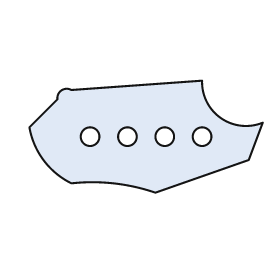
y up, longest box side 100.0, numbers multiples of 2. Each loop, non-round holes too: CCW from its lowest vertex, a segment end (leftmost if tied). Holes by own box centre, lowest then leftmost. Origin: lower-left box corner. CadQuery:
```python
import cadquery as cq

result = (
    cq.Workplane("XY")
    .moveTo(54.0, 0.0)
    .lineTo(94.0, 14.0)
    .lineTo(100.0, 30.0)
    .threePointArc((82.0, 32.0), (74.0, 48.0))
    .lineTo(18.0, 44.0)
    .threePointArc((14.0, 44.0), (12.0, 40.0))
    .lineTo(0.0, 28.0)
    .threePointArc((6.0, 14.0), (18.0, 4.0))
    .threePointArc((36.0, 4.0), (54.0, 0.0))
    .close()
    .moveTo(26.0, 24.0)
    .circle(4.0)
    .moveTo(42.0, 24.0)
    .circle(4.0)
    .moveTo(58.0, 24.0)
    .circle(4.0)
    .moveTo(74.0, 24.0)
    .circle(4.0)
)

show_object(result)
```